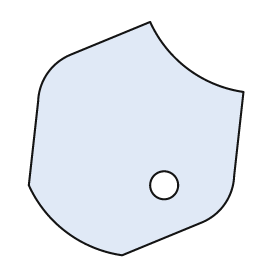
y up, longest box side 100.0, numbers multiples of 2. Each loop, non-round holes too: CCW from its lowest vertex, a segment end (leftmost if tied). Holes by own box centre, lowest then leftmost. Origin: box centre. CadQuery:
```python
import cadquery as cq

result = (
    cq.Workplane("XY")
    .moveTo(-6.0, -50.0)
    .lineTo(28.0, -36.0)
    .threePointArc((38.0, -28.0), (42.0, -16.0))
    .lineTo(46.0, 20.0)
    .threePointArc((22.0, 30.0), (6.0, 50.0))
    .lineTo(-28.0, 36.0)
    .threePointArc((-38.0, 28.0), (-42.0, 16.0))
    .lineTo(-46.0, -20.0)
    .threePointArc((-30.0, -40.0), (-6.0, -50.0))
    .close()
    .moveTo(12.0, -20.0)
    .circle(6.0)
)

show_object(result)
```